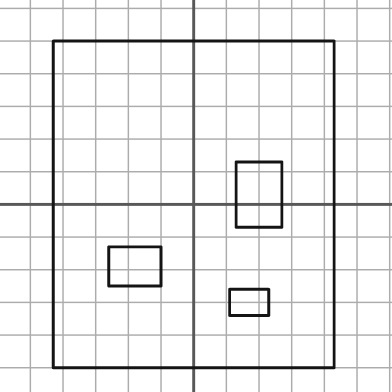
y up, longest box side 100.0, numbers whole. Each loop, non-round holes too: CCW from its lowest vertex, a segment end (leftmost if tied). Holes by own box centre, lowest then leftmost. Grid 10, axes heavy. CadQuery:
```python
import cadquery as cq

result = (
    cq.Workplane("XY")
    .moveTo(-43.0, -50.0)
    .lineTo(43.0, -50.0)
    .lineTo(43.0, 50.0)
    .lineTo(-43.0, 50.0)
    .close()
    .moveTo(11.0, -34.0)
    .lineTo(23.0, -34.0)
    .lineTo(23.0, -26.0)
    .lineTo(11.0, -26.0)
    .close()
    .moveTo(-26.0, -25.0)
    .lineTo(-10.0, -25.0)
    .lineTo(-10.0, -13.0)
    .lineTo(-26.0, -13.0)
    .close()
    .moveTo(13.0, -7.0)
    .lineTo(27.0, -7.0)
    .lineTo(27.0, 13.0)
    .lineTo(13.0, 13.0)
    .close()
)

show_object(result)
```